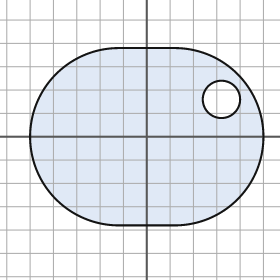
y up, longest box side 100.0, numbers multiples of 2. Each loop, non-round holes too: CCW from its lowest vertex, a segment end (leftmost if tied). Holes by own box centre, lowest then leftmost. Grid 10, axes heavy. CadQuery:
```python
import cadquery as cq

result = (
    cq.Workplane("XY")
    .moveTo(-12.0, -38.0)
    .lineTo(12.0, -38.0)
    .threePointArc((50.0, 0.0), (12.0, 38.0))
    .lineTo(-12.0, 38.0)
    .threePointArc((-50.0, 0.0), (-12.0, -38.0))
    .close()
    .moveTo(32.0, 16.0)
    .circle(8.0)
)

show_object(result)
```